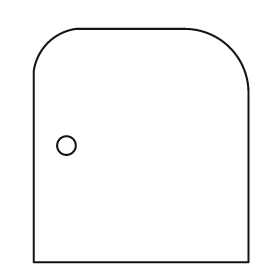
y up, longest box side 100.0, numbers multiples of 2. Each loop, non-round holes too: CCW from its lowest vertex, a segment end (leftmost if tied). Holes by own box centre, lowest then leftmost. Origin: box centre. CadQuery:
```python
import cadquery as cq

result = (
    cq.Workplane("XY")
    .moveTo(-46.0, -50.0)
    .lineTo(46.0, -50.0)
    .lineTo(46.0, 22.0)
    .threePointArc((38.0, 42.0), (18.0, 50.0))
    .lineTo(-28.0, 50.0)
    .threePointArc((-40.0, 44.0), (-46.0, 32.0))
    .close()
    .moveTo(-32.0, 0.0)
    .circle(4.0)
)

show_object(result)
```